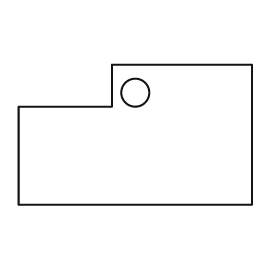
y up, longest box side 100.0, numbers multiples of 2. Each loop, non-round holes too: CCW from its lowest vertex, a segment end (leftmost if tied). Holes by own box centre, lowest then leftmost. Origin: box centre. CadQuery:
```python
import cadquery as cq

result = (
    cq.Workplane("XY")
    .moveTo(-50.0, -30.0)
    .lineTo(50.0, -30.0)
    .lineTo(50.0, 30.0)
    .lineTo(-10.0, 30.0)
    .lineTo(-10.0, 12.0)
    .lineTo(-50.0, 12.0)
    .close()
    .moveTo(0.0, 18.0)
    .circle(6.0)
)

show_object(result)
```